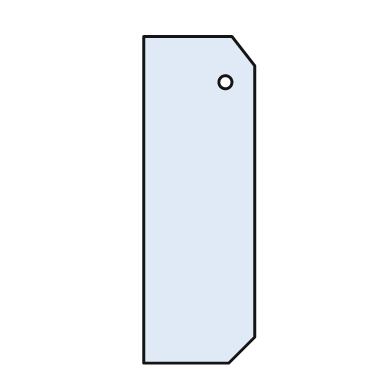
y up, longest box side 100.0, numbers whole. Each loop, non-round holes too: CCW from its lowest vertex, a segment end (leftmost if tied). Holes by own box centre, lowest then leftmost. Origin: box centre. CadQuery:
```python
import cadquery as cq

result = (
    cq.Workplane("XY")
    .moveTo(-17.0, -50.0)
    .lineTo(9.0, -50.0)
    .lineTo(17.0, -42.0)
    .lineTo(17.0, 41.0)
    .lineTo(10.0, 50.0)
    .lineTo(-17.0, 50.0)
    .close()
    .moveTo(8.0, 36.0)
    .circle(2.0)
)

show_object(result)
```